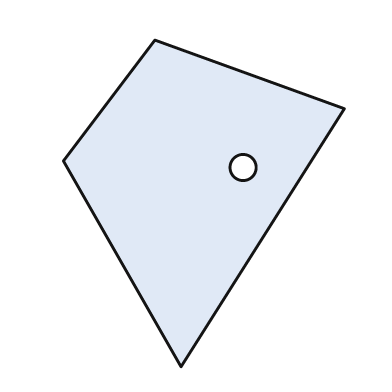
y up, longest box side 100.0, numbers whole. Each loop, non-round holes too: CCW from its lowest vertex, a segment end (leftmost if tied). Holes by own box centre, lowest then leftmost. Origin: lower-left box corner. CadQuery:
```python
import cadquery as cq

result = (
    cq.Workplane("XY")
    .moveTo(36.0, 0.0)
    .lineTo(86.0, 79.0)
    .lineTo(28.0, 100.0)
    .lineTo(0.0, 63.0)
    .close()
    .moveTo(55.0, 61.0)
    .circle(4.0)
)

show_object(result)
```